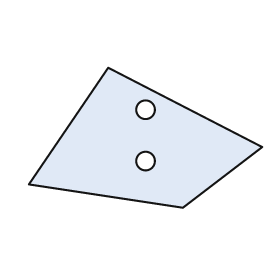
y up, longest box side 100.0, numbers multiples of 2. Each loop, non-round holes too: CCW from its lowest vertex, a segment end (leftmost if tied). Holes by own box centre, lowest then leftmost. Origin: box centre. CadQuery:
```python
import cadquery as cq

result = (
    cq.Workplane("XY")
    .moveTo(16.0, -30.0)
    .lineTo(50.0, -4.0)
    .lineTo(-16.0, 30.0)
    .lineTo(-50.0, -20.0)
    .close()
    .moveTo(0.0, -10.0)
    .circle(4.0)
    .moveTo(0.0, 12.0)
    .circle(4.0)
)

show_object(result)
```